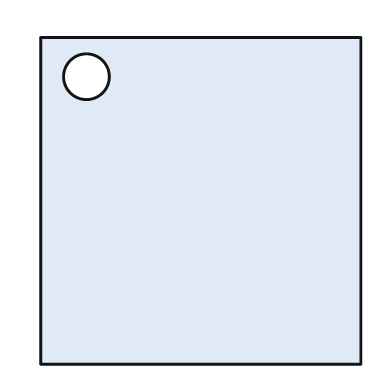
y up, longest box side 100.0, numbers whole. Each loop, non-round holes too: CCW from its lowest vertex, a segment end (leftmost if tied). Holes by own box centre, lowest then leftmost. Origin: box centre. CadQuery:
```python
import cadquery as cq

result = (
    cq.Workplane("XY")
    .moveTo(-49.0, -50.0)
    .lineTo(49.0, -50.0)
    .lineTo(49.0, 50.0)
    .lineTo(-49.0, 50.0)
    .close()
    .moveTo(-35.0, 38.0)
    .circle(7.0)
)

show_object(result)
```